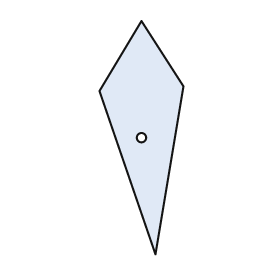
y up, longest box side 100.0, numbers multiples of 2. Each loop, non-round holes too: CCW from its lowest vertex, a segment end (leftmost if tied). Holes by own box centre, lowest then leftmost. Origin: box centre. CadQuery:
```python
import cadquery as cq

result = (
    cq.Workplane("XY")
    .moveTo(6.0, -50.0)
    .lineTo(18.0, 22.0)
    .lineTo(0.0, 50.0)
    .lineTo(-18.0, 20.0)
    .close()
    .moveTo(0.0, 0.0)
    .circle(2.0)
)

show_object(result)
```